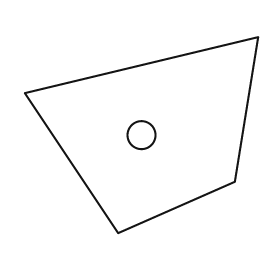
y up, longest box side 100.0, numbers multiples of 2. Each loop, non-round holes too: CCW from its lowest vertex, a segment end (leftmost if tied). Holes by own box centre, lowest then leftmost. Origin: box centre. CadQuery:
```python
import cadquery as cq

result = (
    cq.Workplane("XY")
    .moveTo(-10.0, -42.0)
    .lineTo(40.0, -20.0)
    .lineTo(50.0, 42.0)
    .lineTo(-50.0, 18.0)
    .close()
    .moveTo(0.0, 0.0)
    .circle(6.0)
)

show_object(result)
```